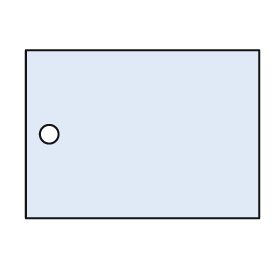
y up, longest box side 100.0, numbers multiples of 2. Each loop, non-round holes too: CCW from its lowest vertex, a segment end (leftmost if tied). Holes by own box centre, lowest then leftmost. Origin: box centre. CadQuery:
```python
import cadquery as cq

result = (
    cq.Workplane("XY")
    .moveTo(-50.0, -36.0)
    .lineTo(50.0, -36.0)
    .lineTo(50.0, 36.0)
    .lineTo(-50.0, 36.0)
    .close()
    .moveTo(-40.0, 0.0)
    .circle(4.0)
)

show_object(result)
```